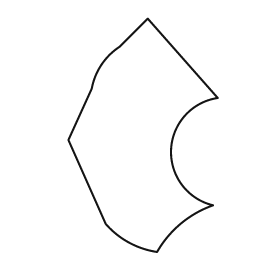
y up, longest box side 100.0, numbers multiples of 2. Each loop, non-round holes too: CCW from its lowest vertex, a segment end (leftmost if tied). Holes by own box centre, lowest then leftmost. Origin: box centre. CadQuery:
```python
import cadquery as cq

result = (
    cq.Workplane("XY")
    .moveTo(6.0, -50.0)
    .threePointArc((16.0, -38.0), (30.0, -30.0))
    .threePointArc((12.0, -6.0), (32.0, 16.0))
    .lineTo(2.0, 50.0)
    .lineTo(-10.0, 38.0)
    .threePointArc((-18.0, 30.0), (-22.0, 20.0))
    .lineTo(-32.0, -2.0)
    .lineTo(-16.0, -38.0)
    .threePointArc((-6.0, -46.0), (6.0, -50.0))
    .close()
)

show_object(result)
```